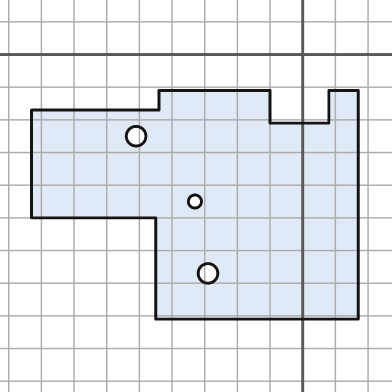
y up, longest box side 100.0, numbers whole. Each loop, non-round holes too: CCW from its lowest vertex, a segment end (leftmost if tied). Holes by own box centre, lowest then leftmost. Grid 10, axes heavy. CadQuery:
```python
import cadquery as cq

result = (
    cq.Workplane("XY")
    .moveTo(-45.0, -81.0)
    .lineTo(17.0, -81.0)
    .lineTo(17.0, -11.0)
    .lineTo(8.0, -11.0)
    .lineTo(8.0, -21.0)
    .lineTo(-10.0, -21.0)
    .lineTo(-10.0, -11.0)
    .lineTo(-44.0, -11.0)
    .lineTo(-44.0, -17.0)
    .lineTo(-83.0, -17.0)
    .lineTo(-83.0, -50.0)
    .lineTo(-45.0, -50.0)
    .close()
    .moveTo(-29.0, -67.0)
    .circle(3.0)
    .moveTo(-33.0, -45.0)
    .circle(2.0)
    .moveTo(-51.0, -25.0)
    .circle(3.0)
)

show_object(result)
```